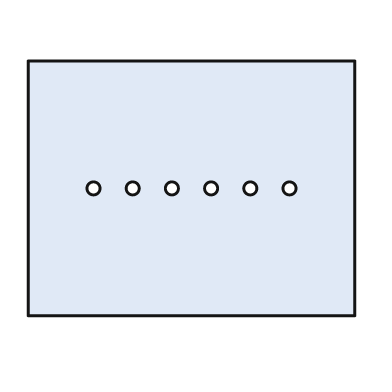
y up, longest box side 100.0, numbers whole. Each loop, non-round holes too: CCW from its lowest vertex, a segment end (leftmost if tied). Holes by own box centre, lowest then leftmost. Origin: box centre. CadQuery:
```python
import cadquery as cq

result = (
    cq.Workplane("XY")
    .moveTo(-50.0, -39.0)
    .lineTo(50.0, -39.0)
    .lineTo(50.0, 39.0)
    .lineTo(-50.0, 39.0)
    .close()
    .moveTo(-30.0, 0.0)
    .circle(2.0)
    .moveTo(-18.0, 0.0)
    .circle(2.0)
    .moveTo(-6.0, 0.0)
    .circle(2.0)
    .moveTo(6.0, 0.0)
    .circle(2.0)
    .moveTo(18.0, 0.0)
    .circle(2.0)
    .moveTo(30.0, 0.0)
    .circle(2.0)
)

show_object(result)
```